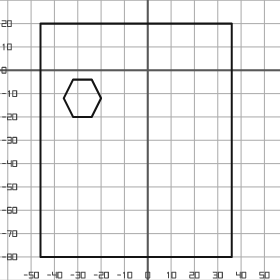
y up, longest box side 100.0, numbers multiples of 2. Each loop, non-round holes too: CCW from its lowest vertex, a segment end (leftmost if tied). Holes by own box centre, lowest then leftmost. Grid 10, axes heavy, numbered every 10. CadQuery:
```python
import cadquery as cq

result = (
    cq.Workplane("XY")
    .moveTo(-46.0, -80.0)
    .lineTo(36.0, -80.0)
    .lineTo(36.0, 20.0)
    .lineTo(-46.0, 20.0)
    .close()
    .moveTo(-32.0, -20.0)
    .lineTo(-24.0, -20.0)
    .lineTo(-20.0, -12.0)
    .lineTo(-24.0, -4.0)
    .lineTo(-32.0, -4.0)
    .lineTo(-36.0, -12.0)
    .close()
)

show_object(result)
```